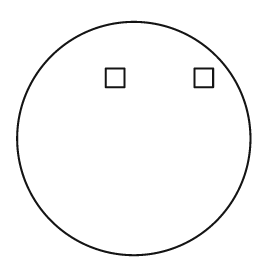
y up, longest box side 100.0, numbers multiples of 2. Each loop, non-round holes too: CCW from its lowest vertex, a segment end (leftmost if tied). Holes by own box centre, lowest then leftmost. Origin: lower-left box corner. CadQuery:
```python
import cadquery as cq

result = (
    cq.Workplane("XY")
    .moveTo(50.0, 50.0)
    .circle(50.0)
    .moveTo(38.0, 72.0)
    .lineTo(46.0, 72.0)
    .lineTo(46.0, 80.0)
    .lineTo(38.0, 80.0)
    .close()
    .moveTo(76.0, 72.0)
    .lineTo(84.0, 72.0)
    .lineTo(84.0, 80.0)
    .lineTo(76.0, 80.0)
    .close()
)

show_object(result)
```